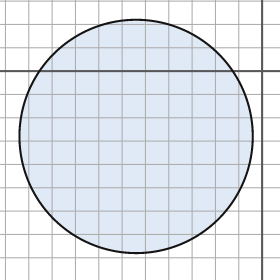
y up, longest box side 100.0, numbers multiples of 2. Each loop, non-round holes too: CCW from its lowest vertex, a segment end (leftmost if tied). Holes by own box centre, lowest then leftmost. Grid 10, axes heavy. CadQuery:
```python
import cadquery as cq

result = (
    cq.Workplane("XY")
    .moveTo(-54.0, -28.0)
    .circle(50.0)
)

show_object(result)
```